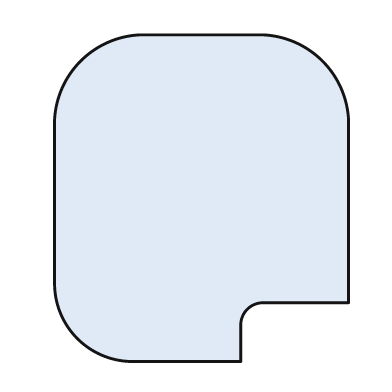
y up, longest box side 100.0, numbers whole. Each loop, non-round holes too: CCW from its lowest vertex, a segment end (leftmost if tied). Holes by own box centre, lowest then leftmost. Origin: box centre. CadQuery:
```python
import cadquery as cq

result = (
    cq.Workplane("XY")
    .moveTo(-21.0, -50.0)
    .lineTo(12.0, -50.0)
    .lineTo(12.0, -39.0)
    .threePointArc((14.0, -34.0), (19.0, -32.0))
    .lineTo(45.0, -32.0)
    .lineTo(45.0, 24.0)
    .threePointArc((37.0, 42.0), (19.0, 50.0))
    .lineTo(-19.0, 50.0)
    .threePointArc((-37.0, 42.0), (-45.0, 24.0))
    .lineTo(-45.0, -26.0)
    .threePointArc((-38.0, -43.0), (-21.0, -50.0))
    .close()
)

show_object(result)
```